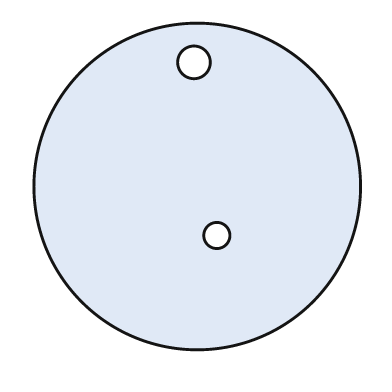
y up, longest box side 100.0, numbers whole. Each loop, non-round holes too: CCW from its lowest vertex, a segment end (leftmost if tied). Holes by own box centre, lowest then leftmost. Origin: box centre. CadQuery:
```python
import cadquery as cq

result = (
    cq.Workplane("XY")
    .moveTo(0.0, 0.0)
    .circle(50.0)
    .moveTo(6.0, -15.0)
    .circle(4.0)
    .moveTo(-1.0, 38.0)
    .circle(5.0)
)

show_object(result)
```